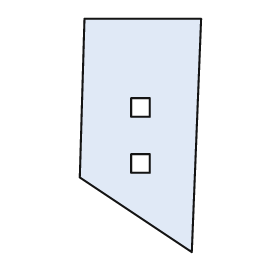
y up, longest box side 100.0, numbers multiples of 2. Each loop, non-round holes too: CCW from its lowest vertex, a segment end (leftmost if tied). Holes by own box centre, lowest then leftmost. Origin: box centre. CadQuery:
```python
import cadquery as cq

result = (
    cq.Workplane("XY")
    .moveTo(22.0, -50.0)
    .lineTo(26.0, 50.0)
    .lineTo(-24.0, 50.0)
    .lineTo(-26.0, -18.0)
    .close()
    .moveTo(-4.0, -16.0)
    .lineTo(4.0, -16.0)
    .lineTo(4.0, -8.0)
    .lineTo(-4.0, -8.0)
    .close()
    .moveTo(-4.0, 8.0)
    .lineTo(4.0, 8.0)
    .lineTo(4.0, 16.0)
    .lineTo(-4.0, 16.0)
    .close()
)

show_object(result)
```